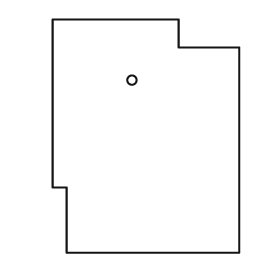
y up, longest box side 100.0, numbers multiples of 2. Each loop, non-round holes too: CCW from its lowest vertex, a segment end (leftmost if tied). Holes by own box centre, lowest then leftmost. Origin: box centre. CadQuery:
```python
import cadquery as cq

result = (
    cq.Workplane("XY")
    .moveTo(-34.0, -50.0)
    .lineTo(40.0, -50.0)
    .lineTo(40.0, 38.0)
    .lineTo(14.0, 38.0)
    .lineTo(14.0, 50.0)
    .lineTo(-40.0, 50.0)
    .lineTo(-40.0, -22.0)
    .lineTo(-34.0, -22.0)
    .close()
    .moveTo(-6.0, 24.0)
    .circle(2.0)
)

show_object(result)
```